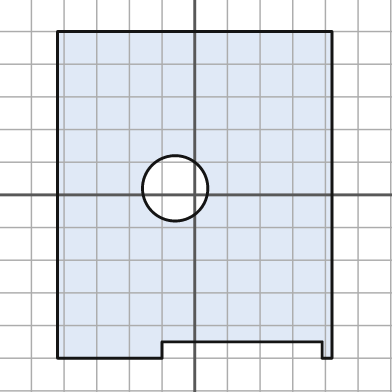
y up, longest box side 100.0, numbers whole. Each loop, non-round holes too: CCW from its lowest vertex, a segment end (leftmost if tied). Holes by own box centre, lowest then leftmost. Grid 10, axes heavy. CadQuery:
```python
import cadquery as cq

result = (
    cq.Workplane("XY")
    .moveTo(-42.0, -50.0)
    .lineTo(-10.0, -50.0)
    .lineTo(-10.0, -45.0)
    .lineTo(39.0, -45.0)
    .lineTo(39.0, -50.0)
    .lineTo(42.0, -50.0)
    .lineTo(42.0, 50.0)
    .lineTo(-42.0, 50.0)
    .close()
    .moveTo(-6.0, 2.0)
    .circle(10.0)
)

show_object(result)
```